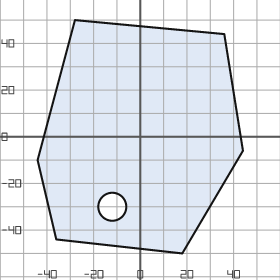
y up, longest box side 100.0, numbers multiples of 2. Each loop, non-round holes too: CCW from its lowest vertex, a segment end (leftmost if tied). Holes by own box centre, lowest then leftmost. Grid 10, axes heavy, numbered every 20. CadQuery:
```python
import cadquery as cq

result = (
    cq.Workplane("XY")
    .moveTo(18.0, -50.0)
    .lineTo(44.0, -6.0)
    .lineTo(36.0, 44.0)
    .lineTo(-28.0, 50.0)
    .lineTo(-44.0, -10.0)
    .lineTo(-36.0, -44.0)
    .close()
    .moveTo(-12.0, -30.0)
    .circle(6.0)
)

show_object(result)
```